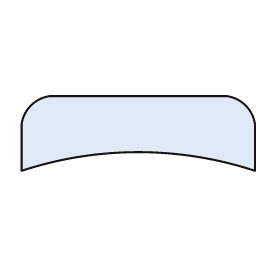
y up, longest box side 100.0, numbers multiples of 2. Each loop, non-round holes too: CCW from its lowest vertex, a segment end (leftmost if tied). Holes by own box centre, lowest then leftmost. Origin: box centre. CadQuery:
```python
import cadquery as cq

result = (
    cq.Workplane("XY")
    .moveTo(-50.0, -16.0)
    .threePointArc((0.0, -8.0), (50.0, -16.0))
    .lineTo(50.0, 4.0)
    .threePointArc((46.0, 12.0), (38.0, 16.0))
    .lineTo(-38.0, 16.0)
    .threePointArc((-46.0, 12.0), (-50.0, 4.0))
    .close()
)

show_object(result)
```